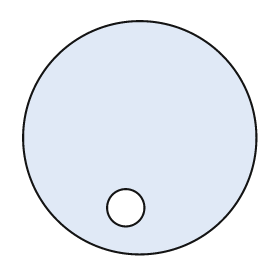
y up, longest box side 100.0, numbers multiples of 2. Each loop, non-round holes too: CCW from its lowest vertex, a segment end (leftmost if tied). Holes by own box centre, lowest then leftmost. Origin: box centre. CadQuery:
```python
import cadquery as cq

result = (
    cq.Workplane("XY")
    .moveTo(0.0, 0.0)
    .circle(50.0)
    .moveTo(-6.0, -30.0)
    .circle(8.0)
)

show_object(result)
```